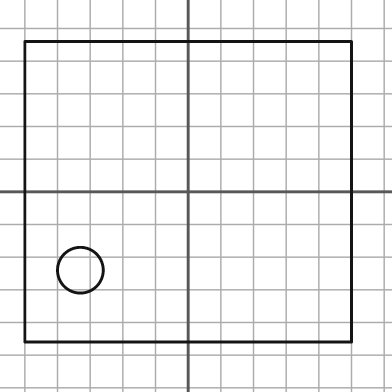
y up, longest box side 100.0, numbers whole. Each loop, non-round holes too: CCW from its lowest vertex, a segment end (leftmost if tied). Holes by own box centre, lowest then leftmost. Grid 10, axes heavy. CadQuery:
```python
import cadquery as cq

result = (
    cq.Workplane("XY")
    .moveTo(-50.0, -46.0)
    .lineTo(50.0, -46.0)
    .lineTo(50.0, 46.0)
    .lineTo(-50.0, 46.0)
    .close()
    .moveTo(-33.0, -24.0)
    .circle(7.0)
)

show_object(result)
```